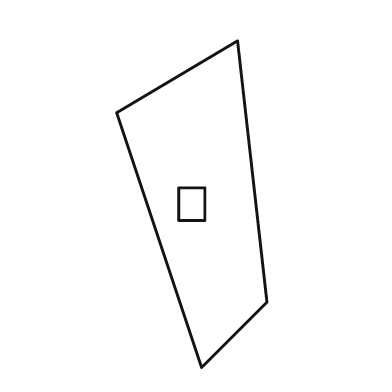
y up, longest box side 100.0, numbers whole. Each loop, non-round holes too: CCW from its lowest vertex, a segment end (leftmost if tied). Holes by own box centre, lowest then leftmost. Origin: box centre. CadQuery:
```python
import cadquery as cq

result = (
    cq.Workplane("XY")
    .moveTo(3.0, -50.0)
    .lineTo(23.0, -30.0)
    .lineTo(14.0, 50.0)
    .lineTo(-23.0, 28.0)
    .close()
    .moveTo(-4.0, -5.0)
    .lineTo(4.0, -5.0)
    .lineTo(4.0, 5.0)
    .lineTo(-4.0, 5.0)
    .close()
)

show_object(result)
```